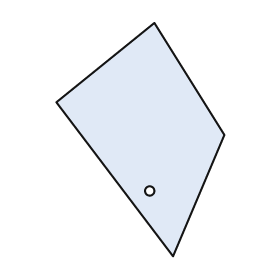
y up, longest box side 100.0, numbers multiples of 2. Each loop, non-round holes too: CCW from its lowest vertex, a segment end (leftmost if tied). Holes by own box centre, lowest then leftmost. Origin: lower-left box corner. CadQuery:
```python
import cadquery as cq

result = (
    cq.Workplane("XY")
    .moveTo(50.0, 0.0)
    .lineTo(72.0, 52.0)
    .lineTo(42.0, 100.0)
    .lineTo(0.0, 66.0)
    .close()
    .moveTo(40.0, 28.0)
    .circle(2.0)
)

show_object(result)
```